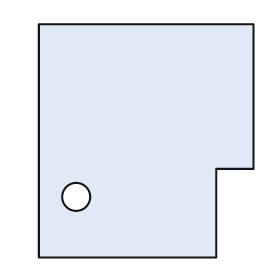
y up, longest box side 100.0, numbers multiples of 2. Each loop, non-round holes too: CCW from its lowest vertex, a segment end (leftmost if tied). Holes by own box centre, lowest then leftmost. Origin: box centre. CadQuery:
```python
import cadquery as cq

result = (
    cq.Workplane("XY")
    .moveTo(-46.0, -50.0)
    .lineTo(30.0, -50.0)
    .lineTo(30.0, -12.0)
    .lineTo(46.0, -12.0)
    .lineTo(46.0, 50.0)
    .lineTo(-46.0, 50.0)
    .close()
    .moveTo(-30.0, -24.0)
    .circle(6.0)
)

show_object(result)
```